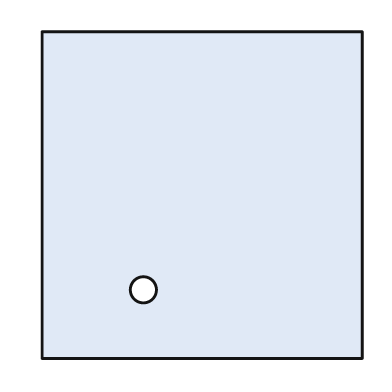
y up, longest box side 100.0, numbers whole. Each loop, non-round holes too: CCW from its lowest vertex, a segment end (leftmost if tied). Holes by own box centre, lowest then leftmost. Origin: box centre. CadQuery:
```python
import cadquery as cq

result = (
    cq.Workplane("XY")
    .moveTo(-49.0, -50.0)
    .lineTo(49.0, -50.0)
    .lineTo(49.0, 50.0)
    .lineTo(-49.0, 50.0)
    .close()
    .moveTo(-18.0, -29.0)
    .circle(4.0)
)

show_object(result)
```